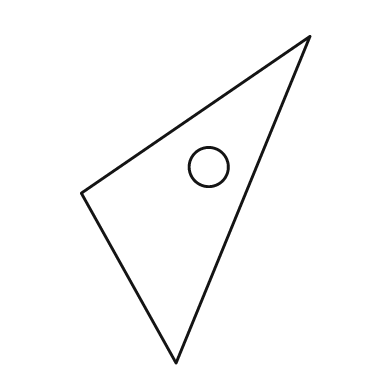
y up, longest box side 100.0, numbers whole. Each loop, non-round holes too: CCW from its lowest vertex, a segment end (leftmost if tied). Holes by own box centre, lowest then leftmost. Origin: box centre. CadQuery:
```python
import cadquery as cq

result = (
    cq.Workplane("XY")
    .moveTo(-6.0, -50.0)
    .lineTo(35.0, 50.0)
    .lineTo(-35.0, 2.0)
    .close()
    .moveTo(4.0, 10.0)
    .circle(6.0)
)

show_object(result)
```